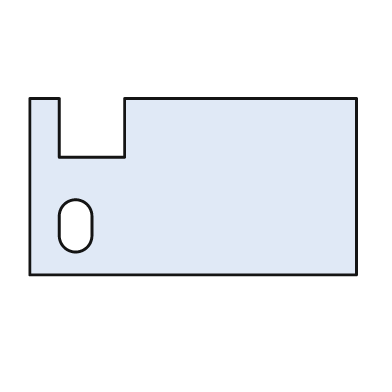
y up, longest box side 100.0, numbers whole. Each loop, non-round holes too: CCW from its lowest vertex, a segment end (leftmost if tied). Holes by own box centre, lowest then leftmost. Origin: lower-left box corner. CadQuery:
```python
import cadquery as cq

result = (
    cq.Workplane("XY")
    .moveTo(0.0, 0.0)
    .lineTo(100.0, 0.0)
    .lineTo(100.0, 54.0)
    .lineTo(29.0, 54.0)
    .lineTo(29.0, 36.0)
    .lineTo(9.0, 36.0)
    .lineTo(9.0, 54.0)
    .lineTo(0.0, 54.0)
    .close()
    .moveTo(9.0, 12.0)
    .threePointArc((14.0, 7.0), (19.0, 12.0))
    .lineTo(19.0, 18.0)
    .threePointArc((14.0, 23.0), (9.0, 18.0))
    .close()
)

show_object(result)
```